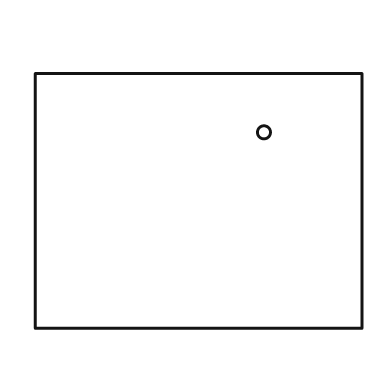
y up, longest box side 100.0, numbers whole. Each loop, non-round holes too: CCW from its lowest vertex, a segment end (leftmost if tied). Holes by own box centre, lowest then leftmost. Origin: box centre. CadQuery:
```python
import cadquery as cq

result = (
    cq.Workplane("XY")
    .moveTo(-50.0, -39.0)
    .lineTo(50.0, -39.0)
    .lineTo(50.0, 39.0)
    .lineTo(-50.0, 39.0)
    .close()
    .moveTo(20.0, 21.0)
    .circle(2.0)
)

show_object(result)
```